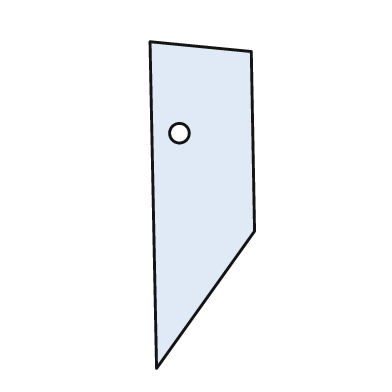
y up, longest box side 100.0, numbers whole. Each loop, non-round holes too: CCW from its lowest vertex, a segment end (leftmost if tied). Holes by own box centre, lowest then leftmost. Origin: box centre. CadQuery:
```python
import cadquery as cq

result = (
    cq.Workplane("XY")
    .moveTo(-14.0, -50.0)
    .lineTo(16.0, -8.0)
    .lineTo(15.0, 47.0)
    .lineTo(-16.0, 50.0)
    .close()
    .moveTo(-7.0, 22.0)
    .circle(3.0)
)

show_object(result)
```